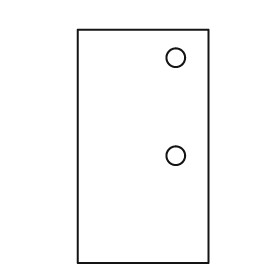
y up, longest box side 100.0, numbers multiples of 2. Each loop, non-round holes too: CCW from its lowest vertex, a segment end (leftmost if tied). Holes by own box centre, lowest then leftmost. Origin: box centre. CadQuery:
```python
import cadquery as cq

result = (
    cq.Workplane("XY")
    .moveTo(-28.0, -50.0)
    .lineTo(28.0, -50.0)
    .lineTo(28.0, 50.0)
    .lineTo(-28.0, 50.0)
    .close()
    .moveTo(14.0, -4.0)
    .circle(4.0)
    .moveTo(14.0, 38.0)
    .circle(4.0)
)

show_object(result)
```